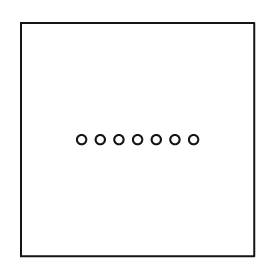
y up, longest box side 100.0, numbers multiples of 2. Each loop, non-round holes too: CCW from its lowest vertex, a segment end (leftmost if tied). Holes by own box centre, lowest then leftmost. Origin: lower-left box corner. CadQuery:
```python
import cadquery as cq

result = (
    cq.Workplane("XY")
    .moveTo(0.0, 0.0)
    .lineTo(100.0, 0.0)
    .lineTo(100.0, 100.0)
    .lineTo(0.0, 100.0)
    .close()
    .moveTo(26.0, 50.0)
    .circle(2.0)
    .moveTo(34.0, 50.0)
    .circle(2.0)
    .moveTo(42.0, 50.0)
    .circle(2.0)
    .moveTo(50.0, 50.0)
    .circle(2.0)
    .moveTo(58.0, 50.0)
    .circle(2.0)
    .moveTo(66.0, 50.0)
    .circle(2.0)
    .moveTo(74.0, 50.0)
    .circle(2.0)
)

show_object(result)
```